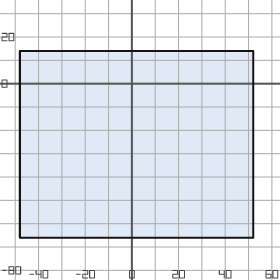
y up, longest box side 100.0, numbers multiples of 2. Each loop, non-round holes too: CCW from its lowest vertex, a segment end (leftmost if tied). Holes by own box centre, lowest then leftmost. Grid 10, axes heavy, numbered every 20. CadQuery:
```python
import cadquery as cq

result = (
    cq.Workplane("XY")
    .moveTo(-48.0, -66.0)
    .lineTo(52.0, -66.0)
    .lineTo(52.0, 14.0)
    .lineTo(-48.0, 14.0)
    .close()
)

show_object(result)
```